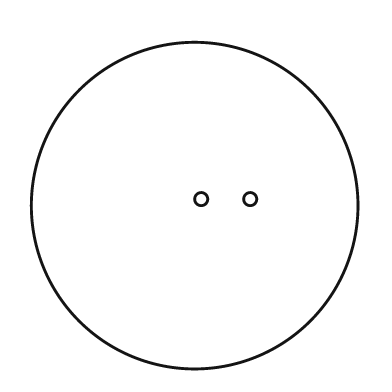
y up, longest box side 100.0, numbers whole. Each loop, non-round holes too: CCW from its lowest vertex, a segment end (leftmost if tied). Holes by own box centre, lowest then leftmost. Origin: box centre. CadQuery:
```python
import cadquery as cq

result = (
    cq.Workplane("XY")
    .moveTo(0.0, 0.0)
    .circle(50.0)
    .moveTo(2.0, 2.0)
    .circle(2.0)
    .moveTo(17.0, 2.0)
    .circle(2.0)
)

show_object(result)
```